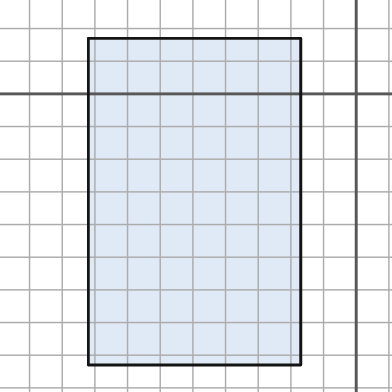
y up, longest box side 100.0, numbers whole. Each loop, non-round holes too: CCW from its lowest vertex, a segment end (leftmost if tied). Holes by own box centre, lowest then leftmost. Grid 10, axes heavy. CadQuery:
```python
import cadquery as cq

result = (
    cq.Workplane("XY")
    .moveTo(-82.0, -83.0)
    .lineTo(-17.0, -83.0)
    .lineTo(-17.0, 17.0)
    .lineTo(-82.0, 17.0)
    .close()
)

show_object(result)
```